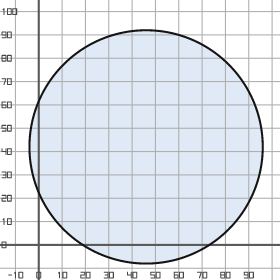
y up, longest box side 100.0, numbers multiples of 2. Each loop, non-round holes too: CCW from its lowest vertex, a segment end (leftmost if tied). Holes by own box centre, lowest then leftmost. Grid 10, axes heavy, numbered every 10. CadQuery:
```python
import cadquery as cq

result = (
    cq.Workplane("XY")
    .moveTo(46.0, 42.0)
    .circle(50.0)
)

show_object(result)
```